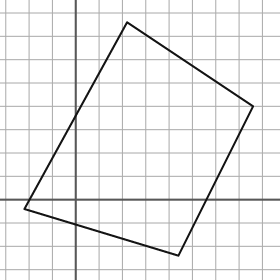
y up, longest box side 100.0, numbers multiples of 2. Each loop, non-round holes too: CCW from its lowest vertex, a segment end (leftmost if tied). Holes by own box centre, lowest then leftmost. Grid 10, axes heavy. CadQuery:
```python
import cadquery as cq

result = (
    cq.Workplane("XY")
    .moveTo(44.0, -24.0)
    .lineTo(76.0, 40.0)
    .lineTo(22.0, 76.0)
    .lineTo(-22.0, -4.0)
    .close()
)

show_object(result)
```